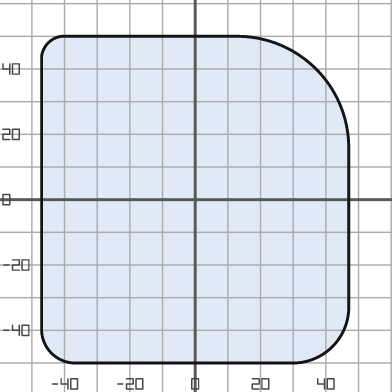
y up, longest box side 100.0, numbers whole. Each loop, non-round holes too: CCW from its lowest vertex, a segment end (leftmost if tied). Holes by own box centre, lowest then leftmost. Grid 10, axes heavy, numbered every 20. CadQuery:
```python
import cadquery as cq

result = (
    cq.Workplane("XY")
    .moveTo(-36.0, -50.0)
    .lineTo(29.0, -50.0)
    .threePointArc((42.0, -45.0), (47.0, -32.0))
    .lineTo(47.0, 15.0)
    .threePointArc((37.0, 40.0), (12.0, 50.0))
    .lineTo(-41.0, 50.0)
    .threePointArc((-45.0, 48.0), (-47.0, 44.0))
    .lineTo(-47.0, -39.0)
    .threePointArc((-44.0, -47.0), (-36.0, -50.0))
    .close()
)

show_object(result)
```